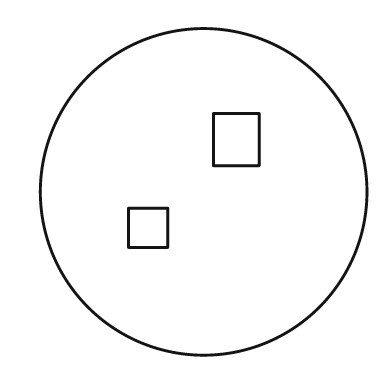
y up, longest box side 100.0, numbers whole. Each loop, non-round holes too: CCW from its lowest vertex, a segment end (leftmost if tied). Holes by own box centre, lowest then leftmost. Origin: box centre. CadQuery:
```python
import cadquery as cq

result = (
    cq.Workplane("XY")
    .moveTo(0.0, 0.0)
    .circle(50.0)
    .moveTo(-23.0, -17.0)
    .lineTo(-11.0, -17.0)
    .lineTo(-11.0, -5.0)
    .lineTo(-23.0, -5.0)
    .close()
    .moveTo(3.0, 8.0)
    .lineTo(17.0, 8.0)
    .lineTo(17.0, 24.0)
    .lineTo(3.0, 24.0)
    .close()
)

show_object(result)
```